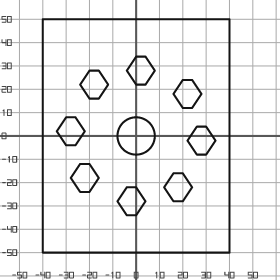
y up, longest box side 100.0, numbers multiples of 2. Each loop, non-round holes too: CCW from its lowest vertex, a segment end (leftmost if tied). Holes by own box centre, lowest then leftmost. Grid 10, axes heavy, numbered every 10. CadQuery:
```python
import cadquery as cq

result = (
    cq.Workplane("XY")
    .moveTo(-40.0, -50.0)
    .lineTo(40.0, -50.0)
    .lineTo(40.0, 50.0)
    .lineTo(-40.0, 50.0)
    .close()
    .moveTo(-4.0, -34.0)
    .lineTo(0.0, -34.0)
    .lineTo(4.0, -28.0)
    .lineTo(0.0, -22.0)
    .lineTo(-4.0, -22.0)
    .lineTo(-8.0, -28.0)
    .close()
    .moveTo(16.0, -28.0)
    .lineTo(20.0, -28.0)
    .lineTo(24.0, -22.0)
    .lineTo(20.0, -16.0)
    .lineTo(16.0, -16.0)
    .lineTo(12.0, -22.0)
    .close()
    .moveTo(-24.0, -24.0)
    .lineTo(-20.0, -24.0)
    .lineTo(-16.0, -18.0)
    .lineTo(-20.0, -12.0)
    .lineTo(-24.0, -12.0)
    .lineTo(-28.0, -18.0)
    .close()
    .moveTo(26.0, -8.0)
    .lineTo(30.0, -8.0)
    .lineTo(34.0, -2.0)
    .lineTo(30.0, 4.0)
    .lineTo(26.0, 4.0)
    .lineTo(22.0, -2.0)
    .close()
    .moveTo(0.0, 0.0)
    .circle(8.0)
    .moveTo(-30.0, -4.0)
    .lineTo(-26.0, -4.0)
    .lineTo(-22.0, 2.0)
    .lineTo(-26.0, 8.0)
    .lineTo(-30.0, 8.0)
    .lineTo(-34.0, 2.0)
    .close()
    .moveTo(20.0, 12.0)
    .lineTo(24.0, 12.0)
    .lineTo(28.0, 18.0)
    .lineTo(24.0, 24.0)
    .lineTo(20.0, 24.0)
    .lineTo(16.0, 18.0)
    .close()
    .moveTo(-20.0, 16.0)
    .lineTo(-16.0, 16.0)
    .lineTo(-12.0, 22.0)
    .lineTo(-16.0, 28.0)
    .lineTo(-20.0, 28.0)
    .lineTo(-24.0, 22.0)
    .close()
    .moveTo(0.0, 22.0)
    .lineTo(4.0, 22.0)
    .lineTo(8.0, 28.0)
    .lineTo(4.0, 34.0)
    .lineTo(0.0, 34.0)
    .lineTo(-4.0, 28.0)
    .close()
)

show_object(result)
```